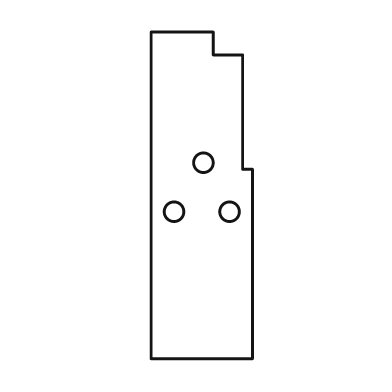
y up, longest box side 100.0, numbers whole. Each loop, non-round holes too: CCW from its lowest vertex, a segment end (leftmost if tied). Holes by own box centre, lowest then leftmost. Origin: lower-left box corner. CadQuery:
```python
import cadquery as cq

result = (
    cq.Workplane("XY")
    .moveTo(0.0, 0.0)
    .lineTo(31.0, 0.0)
    .lineTo(31.0, 58.0)
    .lineTo(28.0, 58.0)
    .lineTo(28.0, 93.0)
    .lineTo(19.0, 93.0)
    .lineTo(19.0, 100.0)
    .lineTo(0.0, 100.0)
    .close()
    .moveTo(7.0, 45.0)
    .circle(3.0)
    .moveTo(24.0, 45.0)
    .circle(3.0)
    .moveTo(16.0, 60.0)
    .circle(3.0)
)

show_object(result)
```